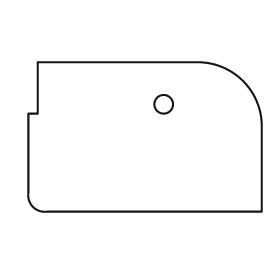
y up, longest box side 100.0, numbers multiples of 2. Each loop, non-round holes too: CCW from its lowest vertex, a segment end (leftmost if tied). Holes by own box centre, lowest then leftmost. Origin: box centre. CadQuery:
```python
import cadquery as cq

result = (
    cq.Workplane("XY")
    .moveTo(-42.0, -32.0)
    .lineTo(50.0, -32.0)
    .lineTo(50.0, 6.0)
    .threePointArc((42.0, 24.0), (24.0, 32.0))
    .lineTo(-46.0, 32.0)
    .lineTo(-46.0, 10.0)
    .lineTo(-50.0, 10.0)
    .lineTo(-50.0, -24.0)
    .threePointArc((-48.0, -30.0), (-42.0, -32.0))
    .close()
    .moveTo(8.0, 14.0)
    .circle(4.0)
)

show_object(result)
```